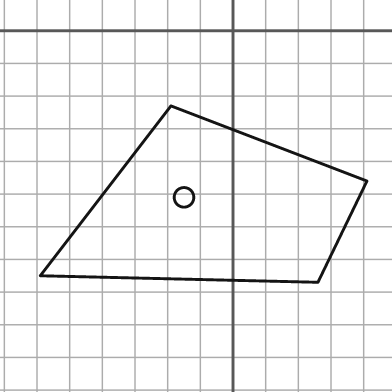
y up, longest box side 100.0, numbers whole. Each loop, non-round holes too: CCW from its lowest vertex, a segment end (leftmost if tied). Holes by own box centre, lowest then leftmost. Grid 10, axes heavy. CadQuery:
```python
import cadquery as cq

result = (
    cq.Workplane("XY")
    .moveTo(26.0, -77.0)
    .lineTo(41.0, -46.0)
    .lineTo(-19.0, -23.0)
    .lineTo(-59.0, -75.0)
    .close()
    .moveTo(-15.0, -51.0)
    .circle(3.0)
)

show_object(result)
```